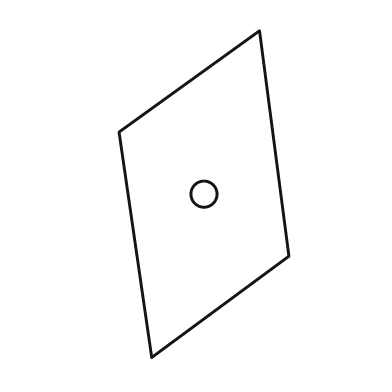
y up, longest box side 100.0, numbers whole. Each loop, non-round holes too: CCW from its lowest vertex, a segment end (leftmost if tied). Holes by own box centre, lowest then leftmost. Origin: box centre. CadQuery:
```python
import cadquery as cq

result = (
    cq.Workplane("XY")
    .moveTo(-16.0, -50.0)
    .lineTo(26.0, -19.0)
    .lineTo(17.0, 50.0)
    .lineTo(-26.0, 19.0)
    .close()
    .moveTo(0.0, 0.0)
    .circle(4.0)
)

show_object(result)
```